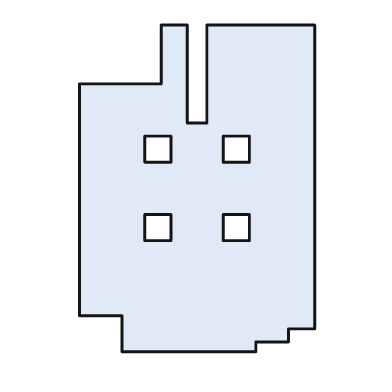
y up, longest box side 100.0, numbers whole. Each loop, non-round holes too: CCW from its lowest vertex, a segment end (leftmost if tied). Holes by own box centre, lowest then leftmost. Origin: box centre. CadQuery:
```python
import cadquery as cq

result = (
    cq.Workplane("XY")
    .moveTo(-23.0, -50.0)
    .lineTo(18.0, -50.0)
    .lineTo(18.0, -47.0)
    .lineTo(28.0, -47.0)
    .lineTo(28.0, -43.0)
    .lineTo(36.0, -43.0)
    .lineTo(36.0, 50.0)
    .lineTo(3.0, 50.0)
    .lineTo(3.0, 20.0)
    .lineTo(-3.0, 20.0)
    .lineTo(-3.0, 50.0)
    .lineTo(-11.0, 50.0)
    .lineTo(-11.0, 32.0)
    .lineTo(-36.0, 32.0)
    .lineTo(-36.0, -39.0)
    .lineTo(-23.0, -39.0)
    .close()
    .moveTo(-16.0, -16.0)
    .lineTo(-8.0, -16.0)
    .lineTo(-8.0, -8.0)
    .lineTo(-16.0, -8.0)
    .close()
    .moveTo(8.0, -16.0)
    .lineTo(16.0, -16.0)
    .lineTo(16.0, -8.0)
    .lineTo(8.0, -8.0)
    .close()
    .moveTo(-16.0, 8.0)
    .lineTo(-8.0, 8.0)
    .lineTo(-8.0, 16.0)
    .lineTo(-16.0, 16.0)
    .close()
    .moveTo(8.0, 8.0)
    .lineTo(16.0, 8.0)
    .lineTo(16.0, 16.0)
    .lineTo(8.0, 16.0)
    .close()
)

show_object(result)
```